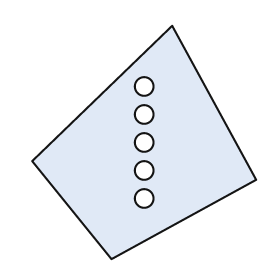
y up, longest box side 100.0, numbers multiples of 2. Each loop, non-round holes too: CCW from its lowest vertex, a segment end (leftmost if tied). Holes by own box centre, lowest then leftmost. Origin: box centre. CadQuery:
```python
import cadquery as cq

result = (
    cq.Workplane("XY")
    .moveTo(-14.0, -50.0)
    .lineTo(48.0, -16.0)
    .lineTo(12.0, 50.0)
    .lineTo(-48.0, -8.0)
    .close()
    .moveTo(0.0, -24.0)
    .circle(4.0)
    .moveTo(0.0, -12.0)
    .circle(4.0)
    .moveTo(0.0, 0.0)
    .circle(4.0)
    .moveTo(0.0, 12.0)
    .circle(4.0)
    .moveTo(0.0, 24.0)
    .circle(4.0)
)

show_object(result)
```